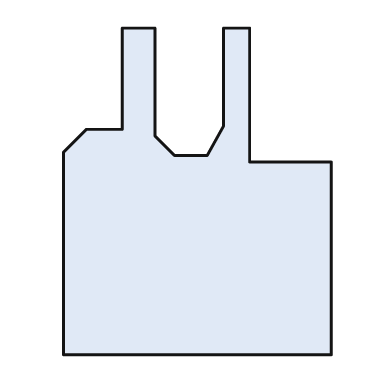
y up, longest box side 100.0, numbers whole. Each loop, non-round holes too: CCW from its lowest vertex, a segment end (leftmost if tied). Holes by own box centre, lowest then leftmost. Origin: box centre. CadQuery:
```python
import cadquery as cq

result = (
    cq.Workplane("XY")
    .moveTo(-41.0, -50.0)
    .lineTo(41.0, -50.0)
    .lineTo(41.0, 9.0)
    .lineTo(16.0, 9.0)
    .lineTo(16.0, 50.0)
    .lineTo(8.0, 50.0)
    .lineTo(8.0, 20.0)
    .lineTo(3.0, 11.0)
    .lineTo(-7.0, 11.0)
    .lineTo(-13.0, 17.0)
    .lineTo(-13.0, 50.0)
    .lineTo(-23.0, 50.0)
    .lineTo(-23.0, 19.0)
    .lineTo(-34.0, 19.0)
    .lineTo(-41.0, 12.0)
    .close()
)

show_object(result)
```